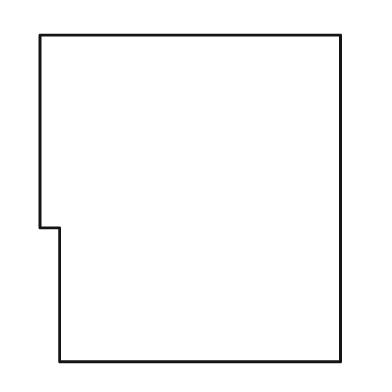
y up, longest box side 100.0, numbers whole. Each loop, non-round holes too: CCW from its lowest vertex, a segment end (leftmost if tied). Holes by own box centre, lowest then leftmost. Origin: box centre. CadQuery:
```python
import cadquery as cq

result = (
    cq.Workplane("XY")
    .moveTo(-40.0, -50.0)
    .lineTo(46.0, -50.0)
    .lineTo(46.0, 50.0)
    .lineTo(-46.0, 50.0)
    .lineTo(-46.0, -9.0)
    .lineTo(-40.0, -9.0)
    .close()
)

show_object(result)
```